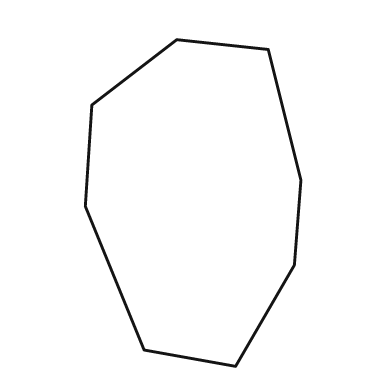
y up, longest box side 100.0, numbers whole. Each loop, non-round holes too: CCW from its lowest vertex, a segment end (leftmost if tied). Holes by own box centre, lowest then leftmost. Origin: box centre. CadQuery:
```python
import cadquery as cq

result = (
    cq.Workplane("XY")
    .moveTo(13.0, -50.0)
    .lineTo(31.0, -19.0)
    .lineTo(33.0, 7.0)
    .lineTo(23.0, 47.0)
    .lineTo(-5.0, 50.0)
    .lineTo(-31.0, 30.0)
    .lineTo(-33.0, -1.0)
    .lineTo(-15.0, -45.0)
    .close()
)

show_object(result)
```